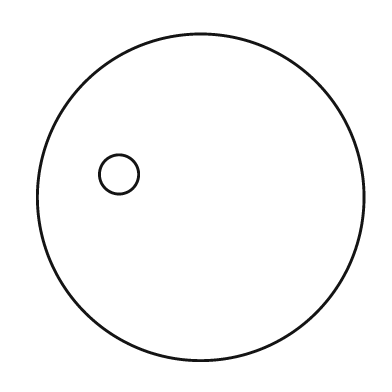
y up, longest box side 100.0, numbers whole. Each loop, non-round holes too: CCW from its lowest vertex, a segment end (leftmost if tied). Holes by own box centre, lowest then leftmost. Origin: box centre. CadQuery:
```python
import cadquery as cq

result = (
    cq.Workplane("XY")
    .moveTo(0.0, 0.0)
    .circle(50.0)
    .moveTo(-25.0, 7.0)
    .circle(6.0)
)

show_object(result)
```